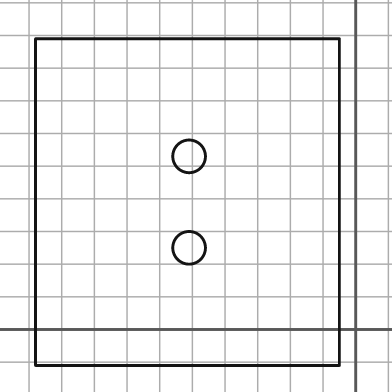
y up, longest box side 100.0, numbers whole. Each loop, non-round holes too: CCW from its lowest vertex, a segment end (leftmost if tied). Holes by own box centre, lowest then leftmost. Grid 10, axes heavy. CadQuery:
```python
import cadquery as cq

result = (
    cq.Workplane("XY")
    .moveTo(-98.0, -11.0)
    .lineTo(-5.0, -11.0)
    .lineTo(-5.0, 89.0)
    .lineTo(-98.0, 89.0)
    .close()
    .moveTo(-51.0, 25.0)
    .circle(5.0)
    .moveTo(-51.0, 53.0)
    .circle(5.0)
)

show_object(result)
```